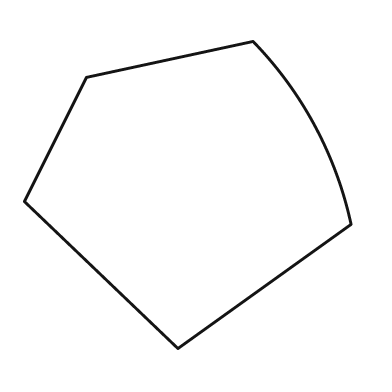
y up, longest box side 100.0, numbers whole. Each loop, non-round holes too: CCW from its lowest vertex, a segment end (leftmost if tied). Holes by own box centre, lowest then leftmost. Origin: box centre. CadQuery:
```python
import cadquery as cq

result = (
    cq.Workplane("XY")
    .moveTo(-3.0, -47.0)
    .lineTo(50.0, -9.0)
    .threePointArc((39.0, 21.0), (20.0, 47.0))
    .lineTo(-31.0, 36.0)
    .lineTo(-50.0, -2.0)
    .close()
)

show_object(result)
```